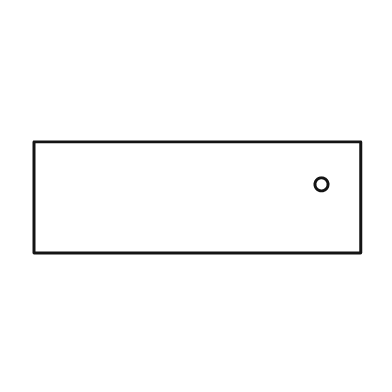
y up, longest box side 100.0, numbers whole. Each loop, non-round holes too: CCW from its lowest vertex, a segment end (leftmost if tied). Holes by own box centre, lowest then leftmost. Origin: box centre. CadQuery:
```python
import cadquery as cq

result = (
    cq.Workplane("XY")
    .moveTo(-50.0, -17.0)
    .lineTo(50.0, -17.0)
    .lineTo(50.0, 17.0)
    .lineTo(-50.0, 17.0)
    .close()
    .moveTo(38.0, 4.0)
    .circle(2.0)
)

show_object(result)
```